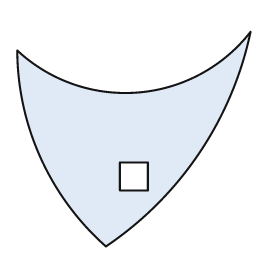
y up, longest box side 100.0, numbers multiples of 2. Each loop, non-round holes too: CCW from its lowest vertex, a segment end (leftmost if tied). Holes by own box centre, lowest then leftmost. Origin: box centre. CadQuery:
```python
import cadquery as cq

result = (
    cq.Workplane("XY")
    .moveTo(-12.0, -46.0)
    .threePointArc((28.0, -6.0), (50.0, 46.0))
    .threePointArc((2.0, 20.0), (-50.0, 38.0))
    .threePointArc((-40.0, -8.0), (-12.0, -46.0))
    .close()
    .moveTo(-6.0, -22.0)
    .lineTo(6.0, -22.0)
    .lineTo(6.0, -10.0)
    .lineTo(-6.0, -10.0)
    .close()
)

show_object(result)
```